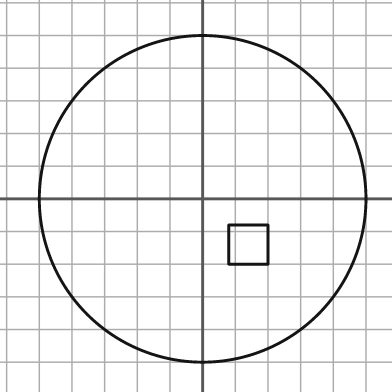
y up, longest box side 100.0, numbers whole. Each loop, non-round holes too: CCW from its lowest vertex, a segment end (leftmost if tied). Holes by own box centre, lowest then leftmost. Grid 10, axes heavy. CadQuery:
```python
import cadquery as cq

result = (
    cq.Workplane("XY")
    .moveTo(0.0, 0.0)
    .circle(50.0)
    .moveTo(8.0, -20.0)
    .lineTo(20.0, -20.0)
    .lineTo(20.0, -8.0)
    .lineTo(8.0, -8.0)
    .close()
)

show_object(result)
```